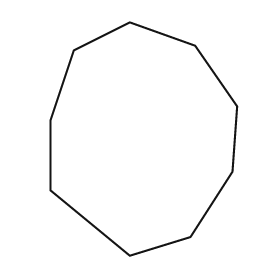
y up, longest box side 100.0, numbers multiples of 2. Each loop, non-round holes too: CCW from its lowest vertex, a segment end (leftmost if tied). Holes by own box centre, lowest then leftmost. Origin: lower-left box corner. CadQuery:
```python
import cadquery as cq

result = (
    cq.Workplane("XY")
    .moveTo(34.0, 0.0)
    .lineTo(60.0, 8.0)
    .lineTo(78.0, 36.0)
    .lineTo(80.0, 64.0)
    .lineTo(62.0, 90.0)
    .lineTo(34.0, 100.0)
    .lineTo(10.0, 88.0)
    .lineTo(0.0, 58.0)
    .lineTo(0.0, 28.0)
    .close()
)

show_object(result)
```